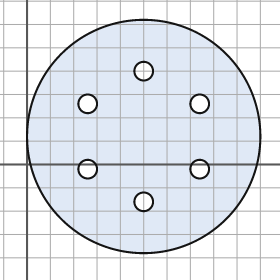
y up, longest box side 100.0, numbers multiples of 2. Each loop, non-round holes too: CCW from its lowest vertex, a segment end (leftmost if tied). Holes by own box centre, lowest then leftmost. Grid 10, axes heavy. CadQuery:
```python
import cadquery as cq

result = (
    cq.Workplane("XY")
    .moveTo(50.0, 12.0)
    .circle(50.0)
    .moveTo(50.0, -16.0)
    .circle(4.0)
    .moveTo(26.0, -2.0)
    .circle(4.0)
    .moveTo(74.0, -2.0)
    .circle(4.0)
    .moveTo(26.0, 26.0)
    .circle(4.0)
    .moveTo(74.0, 26.0)
    .circle(4.0)
    .moveTo(50.0, 40.0)
    .circle(4.0)
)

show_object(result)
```